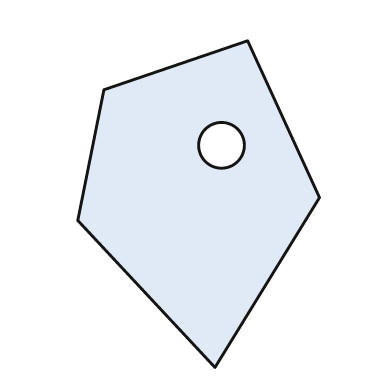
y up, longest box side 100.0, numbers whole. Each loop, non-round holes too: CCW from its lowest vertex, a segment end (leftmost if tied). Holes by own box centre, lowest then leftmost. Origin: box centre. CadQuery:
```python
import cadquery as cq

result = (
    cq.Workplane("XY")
    .moveTo(5.0, -50.0)
    .lineTo(37.0, 2.0)
    .lineTo(15.0, 50.0)
    .lineTo(-29.0, 35.0)
    .lineTo(-37.0, -5.0)
    .close()
    .moveTo(7.0, 18.0)
    .circle(7.0)
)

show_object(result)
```